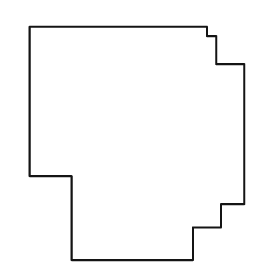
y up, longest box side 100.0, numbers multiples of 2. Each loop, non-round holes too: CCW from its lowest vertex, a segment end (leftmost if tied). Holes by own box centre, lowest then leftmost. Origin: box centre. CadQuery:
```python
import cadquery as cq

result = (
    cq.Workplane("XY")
    .moveTo(-28.0, -50.0)
    .lineTo(24.0, -50.0)
    .lineTo(24.0, -36.0)
    .lineTo(36.0, -36.0)
    .lineTo(36.0, -26.0)
    .lineTo(46.0, -26.0)
    .lineTo(46.0, 34.0)
    .lineTo(34.0, 34.0)
    .lineTo(34.0, 46.0)
    .lineTo(30.0, 46.0)
    .lineTo(30.0, 50.0)
    .lineTo(-46.0, 50.0)
    .lineTo(-46.0, -14.0)
    .lineTo(-28.0, -14.0)
    .close()
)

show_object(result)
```